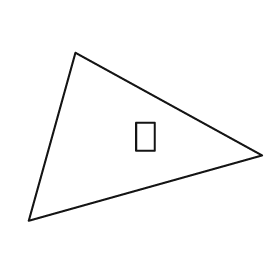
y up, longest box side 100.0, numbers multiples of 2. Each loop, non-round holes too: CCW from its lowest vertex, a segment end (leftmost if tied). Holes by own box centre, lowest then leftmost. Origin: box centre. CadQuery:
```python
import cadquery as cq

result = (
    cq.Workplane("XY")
    .moveTo(-50.0, -36.0)
    .lineTo(50.0, -8.0)
    .lineTo(-30.0, 36.0)
    .close()
    .moveTo(-4.0, -6.0)
    .lineTo(4.0, -6.0)
    .lineTo(4.0, 6.0)
    .lineTo(-4.0, 6.0)
    .close()
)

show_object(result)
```